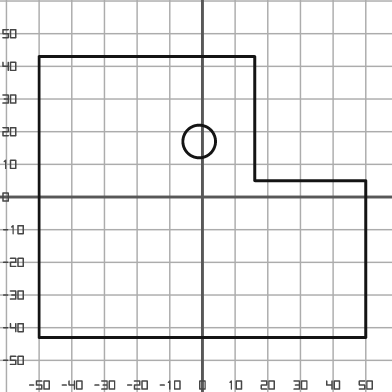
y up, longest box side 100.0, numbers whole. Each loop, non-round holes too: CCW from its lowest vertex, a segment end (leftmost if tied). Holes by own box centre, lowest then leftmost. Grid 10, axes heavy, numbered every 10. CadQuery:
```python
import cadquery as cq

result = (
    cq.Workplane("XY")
    .moveTo(-50.0, -43.0)
    .lineTo(50.0, -43.0)
    .lineTo(50.0, 5.0)
    .lineTo(16.0, 5.0)
    .lineTo(16.0, 43.0)
    .lineTo(-50.0, 43.0)
    .close()
    .moveTo(-1.0, 17.0)
    .circle(5.0)
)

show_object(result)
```